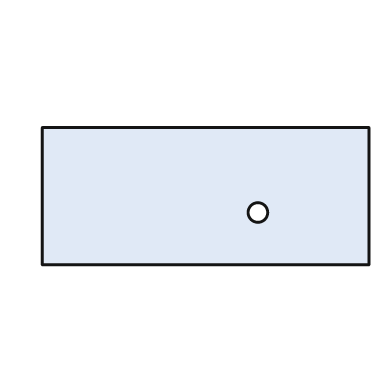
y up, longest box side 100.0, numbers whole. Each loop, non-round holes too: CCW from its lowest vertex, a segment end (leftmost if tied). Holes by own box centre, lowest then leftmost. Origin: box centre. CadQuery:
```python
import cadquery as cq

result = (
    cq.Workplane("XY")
    .moveTo(-50.0, -21.0)
    .lineTo(50.0, -21.0)
    .lineTo(50.0, 21.0)
    .lineTo(-50.0, 21.0)
    .close()
    .moveTo(16.0, -5.0)
    .circle(3.0)
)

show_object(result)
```